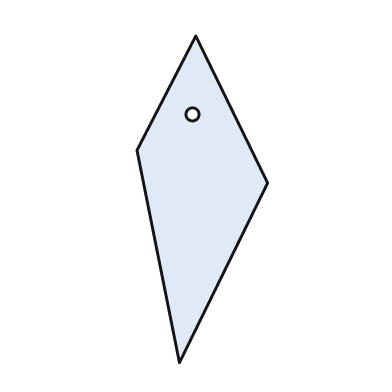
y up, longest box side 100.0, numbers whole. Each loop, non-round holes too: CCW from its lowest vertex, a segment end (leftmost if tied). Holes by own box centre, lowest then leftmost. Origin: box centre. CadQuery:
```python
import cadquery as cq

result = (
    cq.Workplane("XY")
    .moveTo(-7.0, -50.0)
    .lineTo(20.0, 5.0)
    .lineTo(-2.0, 50.0)
    .lineTo(-20.0, 15.0)
    .close()
    .moveTo(-3.0, 26.0)
    .circle(2.0)
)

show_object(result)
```